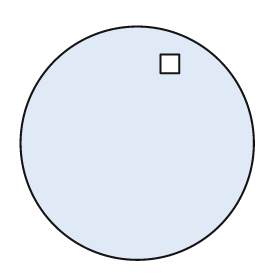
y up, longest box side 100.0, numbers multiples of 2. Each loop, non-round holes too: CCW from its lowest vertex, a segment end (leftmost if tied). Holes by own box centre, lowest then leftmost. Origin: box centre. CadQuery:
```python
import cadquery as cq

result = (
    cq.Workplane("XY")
    .moveTo(0.0, 0.0)
    .circle(50.0)
    .moveTo(10.0, 30.0)
    .lineTo(18.0, 30.0)
    .lineTo(18.0, 38.0)
    .lineTo(10.0, 38.0)
    .close()
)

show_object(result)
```